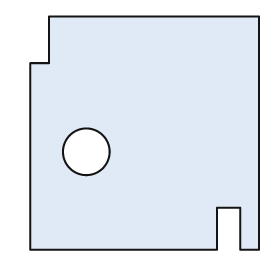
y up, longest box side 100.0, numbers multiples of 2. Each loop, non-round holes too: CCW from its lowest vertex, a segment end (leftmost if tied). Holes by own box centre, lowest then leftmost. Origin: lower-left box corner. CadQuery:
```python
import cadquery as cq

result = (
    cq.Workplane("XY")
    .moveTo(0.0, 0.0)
    .lineTo(80.0, 0.0)
    .lineTo(80.0, 18.0)
    .lineTo(90.0, 18.0)
    .lineTo(90.0, 0.0)
    .lineTo(98.0, 0.0)
    .lineTo(98.0, 100.0)
    .lineTo(8.0, 100.0)
    .lineTo(8.0, 80.0)
    .lineTo(0.0, 80.0)
    .close()
    .moveTo(24.0, 42.0)
    .circle(10.0)
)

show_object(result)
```